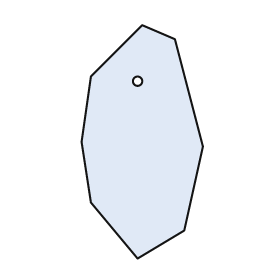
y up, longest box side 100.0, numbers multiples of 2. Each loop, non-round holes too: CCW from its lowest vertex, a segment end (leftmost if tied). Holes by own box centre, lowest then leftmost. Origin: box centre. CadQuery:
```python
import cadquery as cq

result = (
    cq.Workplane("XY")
    .moveTo(-2.0, -50.0)
    .lineTo(18.0, -38.0)
    .lineTo(26.0, -2.0)
    .lineTo(14.0, 44.0)
    .lineTo(0.0, 50.0)
    .lineTo(-22.0, 28.0)
    .lineTo(-26.0, 0.0)
    .lineTo(-22.0, -26.0)
    .close()
    .moveTo(-2.0, 26.0)
    .circle(2.0)
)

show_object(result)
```